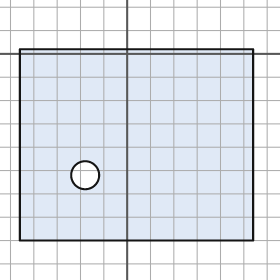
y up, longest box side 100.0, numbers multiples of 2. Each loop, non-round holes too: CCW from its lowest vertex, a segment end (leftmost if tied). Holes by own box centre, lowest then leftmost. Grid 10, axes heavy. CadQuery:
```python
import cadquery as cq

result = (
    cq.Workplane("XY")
    .moveTo(-46.0, -80.0)
    .lineTo(54.0, -80.0)
    .lineTo(54.0, 2.0)
    .lineTo(-46.0, 2.0)
    .close()
    .moveTo(-18.0, -52.0)
    .circle(6.0)
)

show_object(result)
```